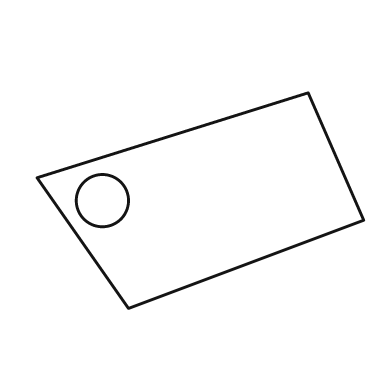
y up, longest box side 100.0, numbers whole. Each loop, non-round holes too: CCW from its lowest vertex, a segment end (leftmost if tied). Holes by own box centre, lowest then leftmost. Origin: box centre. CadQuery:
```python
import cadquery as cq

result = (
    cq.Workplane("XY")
    .moveTo(-22.0, -33.0)
    .lineTo(50.0, -6.0)
    .lineTo(33.0, 33.0)
    .lineTo(-50.0, 7.0)
    .close()
    .moveTo(-30.0, 0.0)
    .circle(8.0)
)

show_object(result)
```